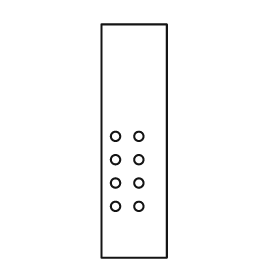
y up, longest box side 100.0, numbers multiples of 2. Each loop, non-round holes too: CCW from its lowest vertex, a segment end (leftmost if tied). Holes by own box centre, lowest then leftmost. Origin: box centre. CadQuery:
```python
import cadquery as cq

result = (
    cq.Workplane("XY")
    .moveTo(-14.0, -50.0)
    .lineTo(14.0, -50.0)
    .lineTo(14.0, 50.0)
    .lineTo(-14.0, 50.0)
    .close()
    .moveTo(-8.0, -28.0)
    .circle(2.0)
    .moveTo(2.0, -28.0)
    .circle(2.0)
    .moveTo(-8.0, -18.0)
    .circle(2.0)
    .moveTo(2.0, -18.0)
    .circle(2.0)
    .moveTo(-8.0, -8.0)
    .circle(2.0)
    .moveTo(2.0, -8.0)
    .circle(2.0)
    .moveTo(-8.0, 2.0)
    .circle(2.0)
    .moveTo(2.0, 2.0)
    .circle(2.0)
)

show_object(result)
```